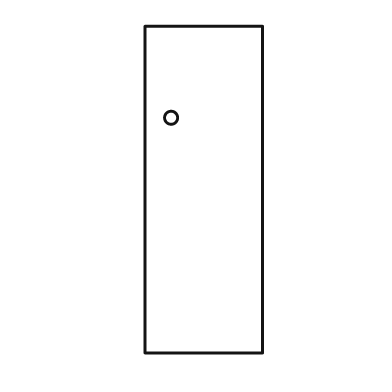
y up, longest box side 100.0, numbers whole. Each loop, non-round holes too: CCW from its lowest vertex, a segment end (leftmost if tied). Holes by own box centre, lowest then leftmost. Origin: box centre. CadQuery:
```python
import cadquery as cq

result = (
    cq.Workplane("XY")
    .moveTo(-18.0, -50.0)
    .lineTo(18.0, -50.0)
    .lineTo(18.0, 50.0)
    .lineTo(-18.0, 50.0)
    .close()
    .moveTo(-10.0, 22.0)
    .circle(2.0)
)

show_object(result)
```